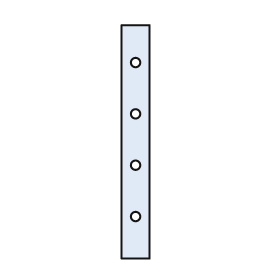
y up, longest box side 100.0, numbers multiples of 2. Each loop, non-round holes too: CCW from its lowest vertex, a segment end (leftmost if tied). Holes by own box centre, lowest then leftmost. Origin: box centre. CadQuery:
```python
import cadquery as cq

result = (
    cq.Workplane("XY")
    .moveTo(-6.0, -50.0)
    .lineTo(6.0, -50.0)
    .lineTo(6.0, 50.0)
    .lineTo(-6.0, 50.0)
    .close()
    .moveTo(0.0, -32.0)
    .circle(2.0)
    .moveTo(0.0, -10.0)
    .circle(2.0)
    .moveTo(0.0, 12.0)
    .circle(2.0)
    .moveTo(0.0, 34.0)
    .circle(2.0)
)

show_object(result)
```